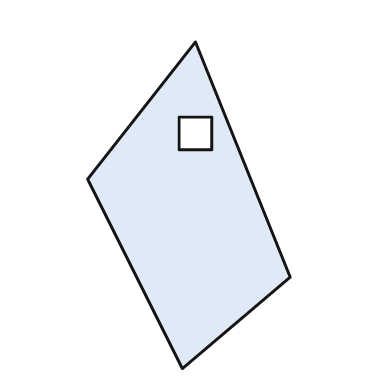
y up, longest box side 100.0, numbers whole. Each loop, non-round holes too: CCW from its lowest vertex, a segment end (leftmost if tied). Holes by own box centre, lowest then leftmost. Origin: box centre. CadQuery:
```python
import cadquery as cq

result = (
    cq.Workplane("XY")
    .moveTo(-2.0, -50.0)
    .lineTo(31.0, -22.0)
    .lineTo(2.0, 50.0)
    .lineTo(-31.0, 8.0)
    .close()
    .moveTo(-3.0, 17.0)
    .lineTo(7.0, 17.0)
    .lineTo(7.0, 27.0)
    .lineTo(-3.0, 27.0)
    .close()
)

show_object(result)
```